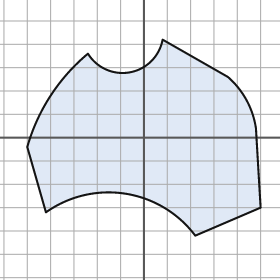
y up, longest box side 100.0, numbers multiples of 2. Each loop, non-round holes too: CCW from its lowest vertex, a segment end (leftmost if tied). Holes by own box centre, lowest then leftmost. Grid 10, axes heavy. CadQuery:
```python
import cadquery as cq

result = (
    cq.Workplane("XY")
    .moveTo(22.0, -42.0)
    .lineTo(50.0, -30.0)
    .lineTo(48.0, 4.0)
    .threePointArc((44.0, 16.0), (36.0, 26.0))
    .lineTo(8.0, 42.0)
    .threePointArc((-6.0, 28.0), (-24.0, 36.0))
    .threePointArc((-40.0, 18.0), (-50.0, -4.0))
    .lineTo(-42.0, -32.0)
    .threePointArc((-8.0, -24.0), (22.0, -42.0))
    .close()
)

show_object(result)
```